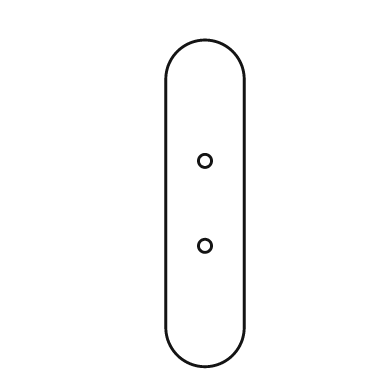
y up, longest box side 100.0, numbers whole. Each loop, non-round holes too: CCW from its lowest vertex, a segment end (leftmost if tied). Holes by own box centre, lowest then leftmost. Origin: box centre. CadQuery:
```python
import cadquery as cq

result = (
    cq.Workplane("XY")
    .moveTo(-12.0, -38.0)
    .threePointArc((0.0, -50.0), (12.0, -38.0))
    .lineTo(12.0, 38.0)
    .threePointArc((0.0, 50.0), (-12.0, 38.0))
    .close()
    .moveTo(0.0, -13.0)
    .circle(2.0)
    .moveTo(0.0, 13.0)
    .circle(2.0)
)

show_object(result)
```